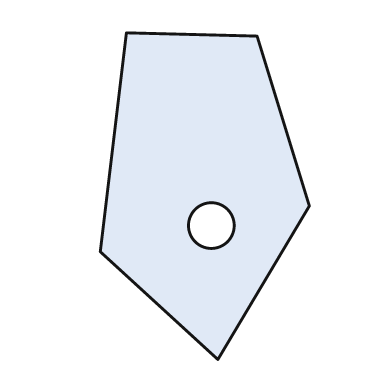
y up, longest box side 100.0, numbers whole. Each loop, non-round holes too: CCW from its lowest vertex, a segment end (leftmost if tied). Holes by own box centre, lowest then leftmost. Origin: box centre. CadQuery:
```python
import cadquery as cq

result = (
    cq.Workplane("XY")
    .moveTo(4.0, -50.0)
    .lineTo(32.0, -3.0)
    .lineTo(16.0, 49.0)
    .lineTo(-24.0, 50.0)
    .lineTo(-32.0, -17.0)
    .close()
    .moveTo(2.0, -9.0)
    .circle(7.0)
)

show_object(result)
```